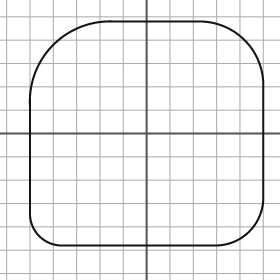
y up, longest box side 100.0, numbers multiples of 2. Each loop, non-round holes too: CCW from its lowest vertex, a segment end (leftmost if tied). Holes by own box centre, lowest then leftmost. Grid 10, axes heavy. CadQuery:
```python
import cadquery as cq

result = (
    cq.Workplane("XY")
    .moveTo(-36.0, -48.0)
    .lineTo(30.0, -48.0)
    .threePointArc((44.0, -42.0), (50.0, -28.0))
    .lineTo(50.0, 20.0)
    .threePointArc((42.0, 40.0), (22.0, 48.0))
    .lineTo(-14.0, 48.0)
    .threePointArc((-40.0, 38.0), (-50.0, 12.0))
    .lineTo(-50.0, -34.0)
    .threePointArc((-46.0, -44.0), (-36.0, -48.0))
    .close()
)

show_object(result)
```